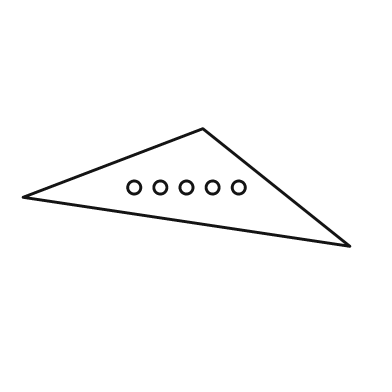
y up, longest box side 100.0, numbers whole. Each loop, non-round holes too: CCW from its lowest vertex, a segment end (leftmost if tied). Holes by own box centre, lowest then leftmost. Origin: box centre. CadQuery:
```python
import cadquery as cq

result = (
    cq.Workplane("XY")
    .moveTo(50.0, -18.0)
    .lineTo(5.0, 18.0)
    .lineTo(-50.0, -3.0)
    .close()
    .moveTo(-16.0, 0.0)
    .circle(2.0)
    .moveTo(-8.0, 0.0)
    .circle(2.0)
    .moveTo(0.0, 0.0)
    .circle(2.0)
    .moveTo(8.0, 0.0)
    .circle(2.0)
    .moveTo(16.0, 0.0)
    .circle(2.0)
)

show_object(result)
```